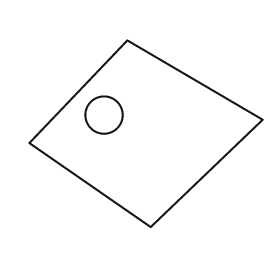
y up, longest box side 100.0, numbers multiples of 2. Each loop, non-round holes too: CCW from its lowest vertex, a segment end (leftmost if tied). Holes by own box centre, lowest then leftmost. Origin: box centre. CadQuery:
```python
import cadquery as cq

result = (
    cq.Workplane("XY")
    .moveTo(2.0, -40.0)
    .lineTo(50.0, 6.0)
    .lineTo(-8.0, 40.0)
    .lineTo(-50.0, -4.0)
    .close()
    .moveTo(-18.0, 8.0)
    .circle(8.0)
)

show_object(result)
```